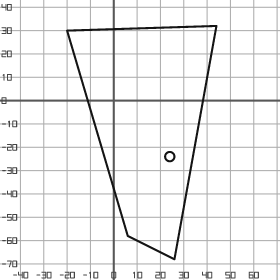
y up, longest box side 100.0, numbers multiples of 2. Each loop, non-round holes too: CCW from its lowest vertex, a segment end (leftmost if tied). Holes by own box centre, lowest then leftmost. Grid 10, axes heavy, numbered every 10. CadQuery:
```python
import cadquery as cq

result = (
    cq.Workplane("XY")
    .moveTo(26.0, -68.0)
    .lineTo(44.0, 32.0)
    .lineTo(-20.0, 30.0)
    .lineTo(6.0, -58.0)
    .close()
    .moveTo(24.0, -24.0)
    .circle(2.0)
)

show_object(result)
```